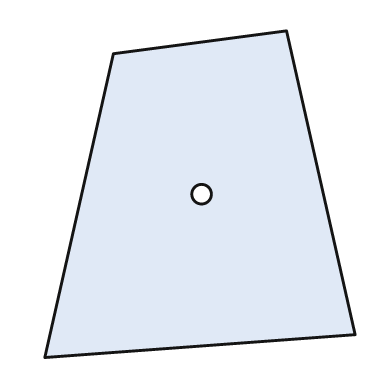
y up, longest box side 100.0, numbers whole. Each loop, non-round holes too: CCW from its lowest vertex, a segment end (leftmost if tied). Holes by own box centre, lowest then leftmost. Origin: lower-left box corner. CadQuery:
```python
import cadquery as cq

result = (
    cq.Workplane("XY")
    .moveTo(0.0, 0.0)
    .lineTo(95.0, 7.0)
    .lineTo(74.0, 100.0)
    .lineTo(21.0, 93.0)
    .close()
    .moveTo(48.0, 50.0)
    .circle(3.0)
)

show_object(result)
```